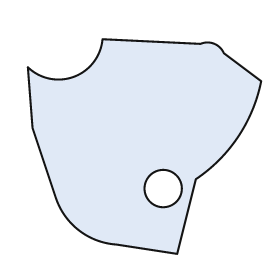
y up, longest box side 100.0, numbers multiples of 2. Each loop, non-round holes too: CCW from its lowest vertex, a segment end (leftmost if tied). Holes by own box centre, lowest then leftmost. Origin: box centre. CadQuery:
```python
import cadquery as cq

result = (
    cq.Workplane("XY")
    .moveTo(14.0, -46.0)
    .lineTo(22.0, -14.0)
    .threePointArc((40.0, 4.0), (50.0, 28.0))
    .lineTo(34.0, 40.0)
    .threePointArc((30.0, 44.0), (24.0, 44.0))
    .lineTo(-18.0, 46.0)
    .threePointArc((-30.0, 30.0), (-50.0, 34.0))
    .lineTo(-48.0, 8.0)
    .lineTo(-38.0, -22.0)
    .threePointArc((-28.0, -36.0), (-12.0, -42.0))
    .close()
    .moveTo(8.0, -18.0)
    .circle(8.0)
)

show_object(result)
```